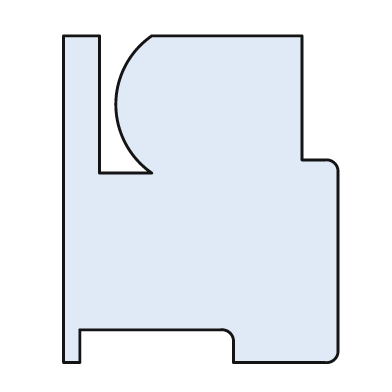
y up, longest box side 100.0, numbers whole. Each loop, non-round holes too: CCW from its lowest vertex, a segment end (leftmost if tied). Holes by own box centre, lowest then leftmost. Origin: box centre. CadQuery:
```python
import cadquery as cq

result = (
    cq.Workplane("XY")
    .moveTo(-42.0, -50.0)
    .lineTo(-37.0, -50.0)
    .lineTo(-37.0, -40.0)
    .lineTo(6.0, -40.0)
    .threePointArc((9.0, -41.0), (10.0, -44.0))
    .lineTo(10.0, -50.0)
    .lineTo(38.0, -50.0)
    .threePointArc((41.0, -49.0), (42.0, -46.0))
    .lineTo(42.0, 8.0)
    .threePointArc((41.0, 11.0), (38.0, 12.0))
    .lineTo(31.0, 12.0)
    .lineTo(31.0, 50.0)
    .lineTo(-15.0, 50.0)
    .threePointArc((-26.0, 29.0), (-15.0, 8.0))
    .lineTo(-31.0, 8.0)
    .lineTo(-31.0, 50.0)
    .lineTo(-42.0, 50.0)
    .close()
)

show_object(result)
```